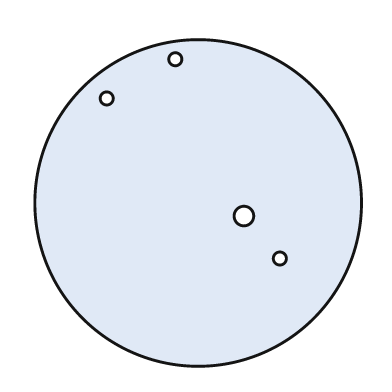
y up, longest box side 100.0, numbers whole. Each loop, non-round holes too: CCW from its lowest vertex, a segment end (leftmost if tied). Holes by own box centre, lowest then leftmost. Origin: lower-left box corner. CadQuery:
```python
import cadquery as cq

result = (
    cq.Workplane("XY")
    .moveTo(50.0, 50.0)
    .circle(50.0)
    .moveTo(75.0, 33.0)
    .circle(2.0)
    .moveTo(64.0, 46.0)
    .circle(3.0)
    .moveTo(22.0, 82.0)
    .circle(2.0)
    .moveTo(43.0, 94.0)
    .circle(2.0)
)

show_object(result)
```